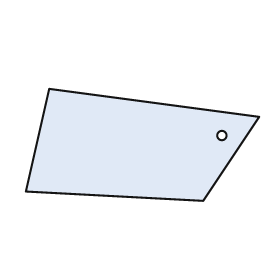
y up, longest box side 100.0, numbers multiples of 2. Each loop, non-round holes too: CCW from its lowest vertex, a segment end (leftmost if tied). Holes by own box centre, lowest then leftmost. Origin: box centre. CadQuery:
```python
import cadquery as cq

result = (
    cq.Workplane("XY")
    .moveTo(26.0, -24.0)
    .lineTo(50.0, 12.0)
    .lineTo(-40.0, 24.0)
    .lineTo(-50.0, -20.0)
    .close()
    .moveTo(34.0, 4.0)
    .circle(2.0)
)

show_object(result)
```